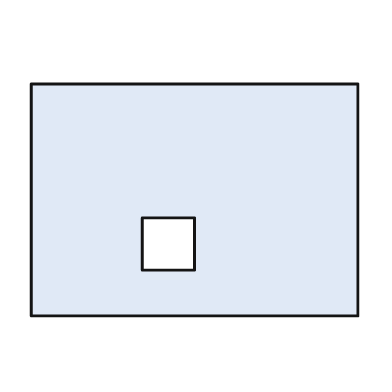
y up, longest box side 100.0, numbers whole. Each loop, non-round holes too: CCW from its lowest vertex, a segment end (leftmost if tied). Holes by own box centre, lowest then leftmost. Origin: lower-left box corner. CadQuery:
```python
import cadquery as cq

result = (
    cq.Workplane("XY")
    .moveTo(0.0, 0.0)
    .lineTo(100.0, 0.0)
    .lineTo(100.0, 71.0)
    .lineTo(0.0, 71.0)
    .close()
    .moveTo(34.0, 14.0)
    .lineTo(50.0, 14.0)
    .lineTo(50.0, 30.0)
    .lineTo(34.0, 30.0)
    .close()
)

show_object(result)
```